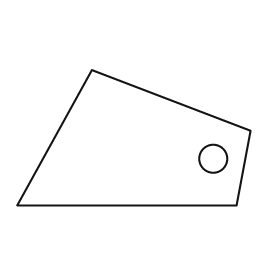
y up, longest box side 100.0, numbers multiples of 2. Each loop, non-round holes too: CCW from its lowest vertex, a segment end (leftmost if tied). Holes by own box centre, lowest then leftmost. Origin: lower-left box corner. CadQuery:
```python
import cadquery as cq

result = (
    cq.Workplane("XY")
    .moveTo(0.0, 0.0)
    .lineTo(94.0, 0.0)
    .lineTo(100.0, 32.0)
    .lineTo(32.0, 58.0)
    .close()
    .moveTo(84.0, 20.0)
    .circle(6.0)
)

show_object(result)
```